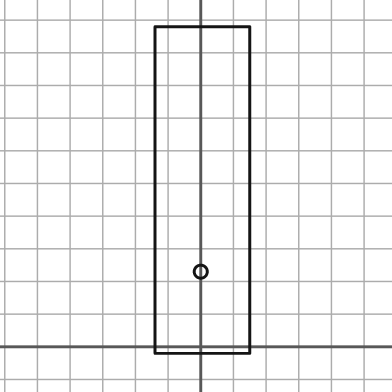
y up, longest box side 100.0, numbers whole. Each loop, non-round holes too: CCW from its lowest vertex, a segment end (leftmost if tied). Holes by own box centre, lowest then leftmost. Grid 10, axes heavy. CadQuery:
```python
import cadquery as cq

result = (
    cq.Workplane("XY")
    .moveTo(-14.0, -2.0)
    .lineTo(15.0, -2.0)
    .lineTo(15.0, 98.0)
    .lineTo(-14.0, 98.0)
    .close()
    .moveTo(0.0, 23.0)
    .circle(2.0)
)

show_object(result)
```